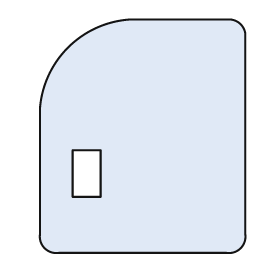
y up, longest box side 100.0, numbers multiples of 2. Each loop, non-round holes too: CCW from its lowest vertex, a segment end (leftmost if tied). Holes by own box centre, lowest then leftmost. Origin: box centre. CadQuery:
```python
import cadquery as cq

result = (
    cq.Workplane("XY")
    .moveTo(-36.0, -50.0)
    .lineTo(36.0, -50.0)
    .threePointArc((42.0, -48.0), (44.0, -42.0))
    .lineTo(44.0, 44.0)
    .threePointArc((42.0, 48.0), (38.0, 50.0))
    .lineTo(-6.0, 50.0)
    .threePointArc((-32.0, 38.0), (-44.0, 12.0))
    .lineTo(-44.0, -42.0)
    .threePointArc((-42.0, -48.0), (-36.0, -50.0))
    .close()
    .moveTo(-30.0, -26.0)
    .lineTo(-18.0, -26.0)
    .lineTo(-18.0, -6.0)
    .lineTo(-30.0, -6.0)
    .close()
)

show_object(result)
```